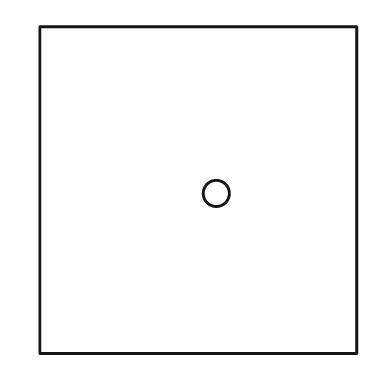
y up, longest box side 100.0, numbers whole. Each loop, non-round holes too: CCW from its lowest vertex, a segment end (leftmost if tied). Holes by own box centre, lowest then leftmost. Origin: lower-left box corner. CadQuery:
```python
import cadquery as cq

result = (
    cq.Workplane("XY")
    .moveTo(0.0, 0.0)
    .lineTo(97.0, 0.0)
    .lineTo(97.0, 100.0)
    .lineTo(0.0, 100.0)
    .close()
    .moveTo(54.0, 49.0)
    .circle(4.0)
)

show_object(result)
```